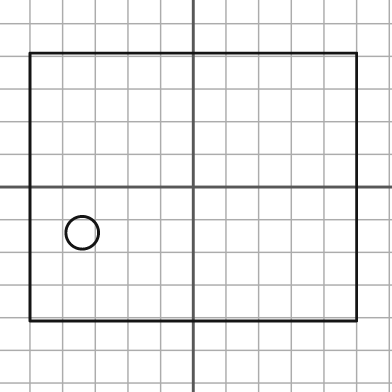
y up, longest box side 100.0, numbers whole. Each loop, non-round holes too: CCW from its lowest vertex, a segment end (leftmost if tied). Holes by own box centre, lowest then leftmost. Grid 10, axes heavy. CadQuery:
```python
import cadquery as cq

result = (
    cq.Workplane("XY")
    .moveTo(-50.0, -41.0)
    .lineTo(50.0, -41.0)
    .lineTo(50.0, 41.0)
    .lineTo(-50.0, 41.0)
    .close()
    .moveTo(-34.0, -14.0)
    .circle(5.0)
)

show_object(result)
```